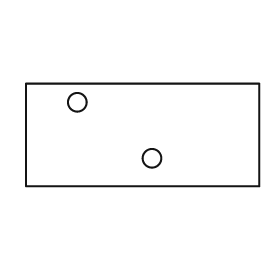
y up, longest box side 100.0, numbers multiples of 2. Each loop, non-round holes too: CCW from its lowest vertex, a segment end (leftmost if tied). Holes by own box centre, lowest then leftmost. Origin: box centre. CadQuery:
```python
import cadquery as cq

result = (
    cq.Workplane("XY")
    .moveTo(-50.0, -22.0)
    .lineTo(50.0, -22.0)
    .lineTo(50.0, 22.0)
    .lineTo(-50.0, 22.0)
    .close()
    .moveTo(4.0, -10.0)
    .circle(4.0)
    .moveTo(-28.0, 14.0)
    .circle(4.0)
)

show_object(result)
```